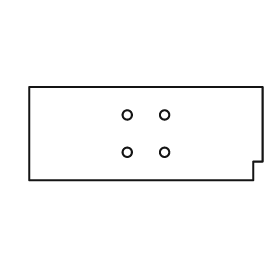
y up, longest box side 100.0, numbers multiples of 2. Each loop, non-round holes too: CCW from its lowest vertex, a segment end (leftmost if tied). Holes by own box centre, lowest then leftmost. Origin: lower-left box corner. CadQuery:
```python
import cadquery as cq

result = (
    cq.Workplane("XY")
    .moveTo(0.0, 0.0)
    .lineTo(96.0, 0.0)
    .lineTo(96.0, 8.0)
    .lineTo(100.0, 8.0)
    .lineTo(100.0, 40.0)
    .lineTo(0.0, 40.0)
    .close()
    .moveTo(42.0, 12.0)
    .circle(2.0)
    .moveTo(58.0, 12.0)
    .circle(2.0)
    .moveTo(42.0, 28.0)
    .circle(2.0)
    .moveTo(58.0, 28.0)
    .circle(2.0)
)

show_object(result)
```